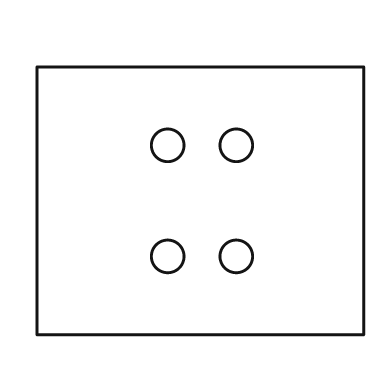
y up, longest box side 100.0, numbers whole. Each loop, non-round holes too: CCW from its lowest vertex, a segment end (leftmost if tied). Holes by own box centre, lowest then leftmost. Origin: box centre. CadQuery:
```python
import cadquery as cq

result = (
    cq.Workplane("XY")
    .moveTo(-50.0, -41.0)
    .lineTo(50.0, -41.0)
    .lineTo(50.0, 41.0)
    .lineTo(-50.0, 41.0)
    .close()
    .moveTo(-10.0, -17.0)
    .circle(5.0)
    .moveTo(11.0, -17.0)
    .circle(5.0)
    .moveTo(-10.0, 17.0)
    .circle(5.0)
    .moveTo(11.0, 17.0)
    .circle(5.0)
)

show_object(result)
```